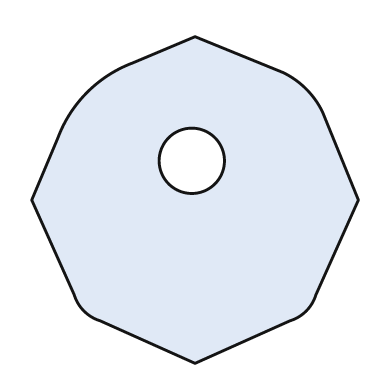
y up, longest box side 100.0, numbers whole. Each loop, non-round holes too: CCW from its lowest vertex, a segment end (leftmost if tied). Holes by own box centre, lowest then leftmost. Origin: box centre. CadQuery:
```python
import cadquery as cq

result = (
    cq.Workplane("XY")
    .moveTo(0.0, -50.0)
    .lineTo(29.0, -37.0)
    .threePointArc((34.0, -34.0), (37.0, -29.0))
    .lineTo(50.0, 0.0)
    .lineTo(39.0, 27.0)
    .threePointArc((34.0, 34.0), (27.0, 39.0))
    .lineTo(0.0, 50.0)
    .lineTo(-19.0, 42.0)
    .threePointArc((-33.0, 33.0), (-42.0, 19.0))
    .lineTo(-50.0, 0.0)
    .lineTo(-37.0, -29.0)
    .threePointArc((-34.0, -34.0), (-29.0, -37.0))
    .close()
    .moveTo(-1.0, 12.0)
    .circle(10.0)
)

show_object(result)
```